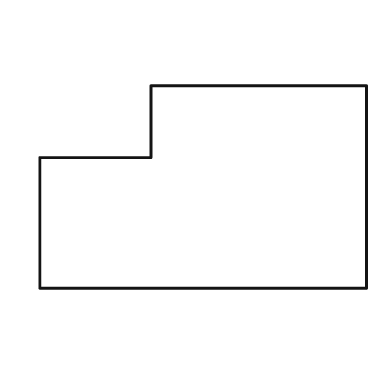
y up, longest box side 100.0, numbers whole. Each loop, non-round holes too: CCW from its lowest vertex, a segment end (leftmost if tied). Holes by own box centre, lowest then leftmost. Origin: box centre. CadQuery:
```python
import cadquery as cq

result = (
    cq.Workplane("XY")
    .moveTo(-50.0, -31.0)
    .lineTo(50.0, -31.0)
    .lineTo(50.0, 31.0)
    .lineTo(-16.0, 31.0)
    .lineTo(-16.0, 9.0)
    .lineTo(-50.0, 9.0)
    .close()
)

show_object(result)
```